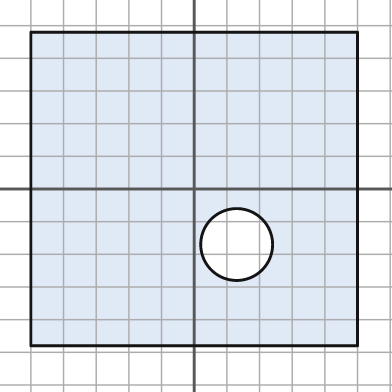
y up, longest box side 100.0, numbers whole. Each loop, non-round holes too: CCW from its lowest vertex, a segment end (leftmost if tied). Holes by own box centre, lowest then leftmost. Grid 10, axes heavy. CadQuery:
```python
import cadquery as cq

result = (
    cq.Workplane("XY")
    .moveTo(-50.0, -48.0)
    .lineTo(50.0, -48.0)
    .lineTo(50.0, 48.0)
    .lineTo(-50.0, 48.0)
    .close()
    .moveTo(13.0, -17.0)
    .circle(11.0)
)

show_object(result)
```